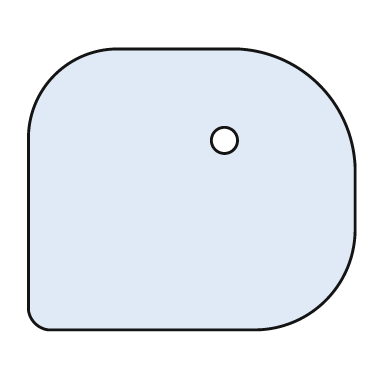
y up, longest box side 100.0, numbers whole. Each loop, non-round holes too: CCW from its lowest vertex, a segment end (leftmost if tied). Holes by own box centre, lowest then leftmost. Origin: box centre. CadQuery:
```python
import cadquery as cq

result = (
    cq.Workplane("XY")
    .moveTo(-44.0, -43.0)
    .lineTo(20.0, -43.0)
    .threePointArc((41.0, -34.0), (50.0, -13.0))
    .lineTo(50.0, 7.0)
    .threePointArc((39.0, 32.0), (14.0, 43.0))
    .lineTo(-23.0, 43.0)
    .threePointArc((-42.0, 35.0), (-50.0, 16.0))
    .lineTo(-50.0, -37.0)
    .threePointArc((-48.0, -41.0), (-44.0, -43.0))
    .close()
    .moveTo(10.0, 15.0)
    .circle(4.0)
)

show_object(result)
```